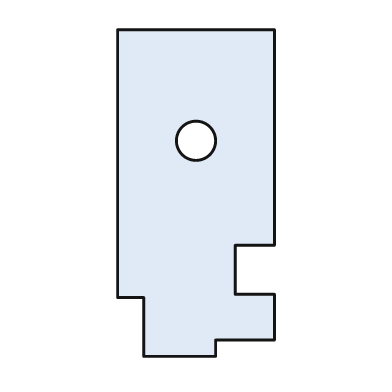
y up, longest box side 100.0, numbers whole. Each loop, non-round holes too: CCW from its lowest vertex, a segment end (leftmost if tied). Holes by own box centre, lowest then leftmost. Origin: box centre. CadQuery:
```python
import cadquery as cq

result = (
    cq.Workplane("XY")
    .moveTo(-16.0, -50.0)
    .lineTo(6.0, -50.0)
    .lineTo(6.0, -45.0)
    .lineTo(24.0, -45.0)
    .lineTo(24.0, -31.0)
    .lineTo(12.0, -31.0)
    .lineTo(12.0, -16.0)
    .lineTo(24.0, -16.0)
    .lineTo(24.0, 50.0)
    .lineTo(-24.0, 50.0)
    .lineTo(-24.0, -32.0)
    .lineTo(-16.0, -32.0)
    .close()
    .moveTo(0.0, 16.0)
    .circle(6.0)
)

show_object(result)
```